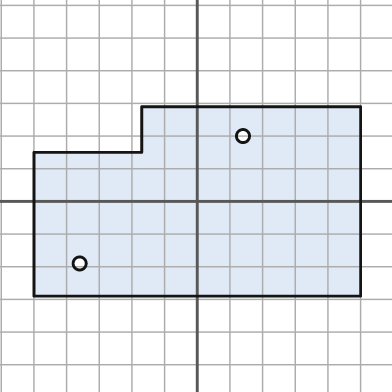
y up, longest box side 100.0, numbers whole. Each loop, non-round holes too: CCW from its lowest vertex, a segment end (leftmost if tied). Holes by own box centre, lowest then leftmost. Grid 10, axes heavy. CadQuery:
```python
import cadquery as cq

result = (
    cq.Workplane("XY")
    .moveTo(-50.0, -29.0)
    .lineTo(50.0, -29.0)
    .lineTo(50.0, 29.0)
    .lineTo(-17.0, 29.0)
    .lineTo(-17.0, 15.0)
    .lineTo(-50.0, 15.0)
    .close()
    .moveTo(-36.0, -19.0)
    .circle(2.0)
    .moveTo(14.0, 20.0)
    .circle(2.0)
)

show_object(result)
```